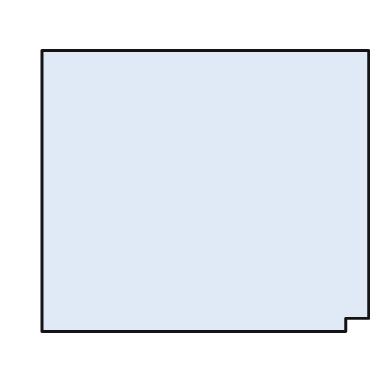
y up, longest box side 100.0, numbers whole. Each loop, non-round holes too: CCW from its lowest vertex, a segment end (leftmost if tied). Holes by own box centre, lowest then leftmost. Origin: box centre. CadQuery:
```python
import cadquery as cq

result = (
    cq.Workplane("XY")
    .moveTo(-50.0, -43.0)
    .lineTo(43.0, -43.0)
    .lineTo(43.0, -39.0)
    .lineTo(50.0, -39.0)
    .lineTo(50.0, 43.0)
    .lineTo(-50.0, 43.0)
    .close()
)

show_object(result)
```